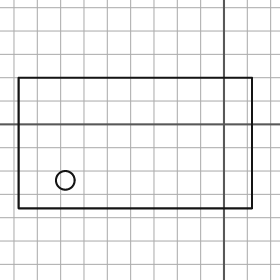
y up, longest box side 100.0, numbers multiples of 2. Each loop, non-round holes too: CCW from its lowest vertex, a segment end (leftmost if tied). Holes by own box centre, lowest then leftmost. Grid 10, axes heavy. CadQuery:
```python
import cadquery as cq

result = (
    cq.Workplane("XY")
    .moveTo(-88.0, -36.0)
    .lineTo(12.0, -36.0)
    .lineTo(12.0, 20.0)
    .lineTo(-88.0, 20.0)
    .close()
    .moveTo(-68.0, -24.0)
    .circle(4.0)
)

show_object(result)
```